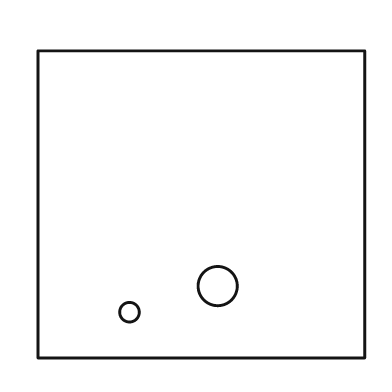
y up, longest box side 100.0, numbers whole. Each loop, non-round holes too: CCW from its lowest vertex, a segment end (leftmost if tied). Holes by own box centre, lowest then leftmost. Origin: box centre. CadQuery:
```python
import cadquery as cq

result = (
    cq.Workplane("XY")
    .moveTo(-50.0, -47.0)
    .lineTo(50.0, -47.0)
    .lineTo(50.0, 47.0)
    .lineTo(-50.0, 47.0)
    .close()
    .moveTo(-22.0, -33.0)
    .circle(3.0)
    .moveTo(5.0, -25.0)
    .circle(6.0)
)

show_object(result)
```